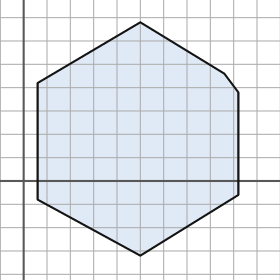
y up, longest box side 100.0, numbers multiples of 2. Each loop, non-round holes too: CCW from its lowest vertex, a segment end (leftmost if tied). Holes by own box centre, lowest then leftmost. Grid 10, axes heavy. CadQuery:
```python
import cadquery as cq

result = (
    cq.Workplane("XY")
    .moveTo(50.0, -32.0)
    .lineTo(92.0, -6.0)
    .lineTo(92.0, 38.0)
    .lineTo(86.0, 46.0)
    .lineTo(50.0, 68.0)
    .lineTo(6.0, 42.0)
    .lineTo(6.0, -8.0)
    .close()
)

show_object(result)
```